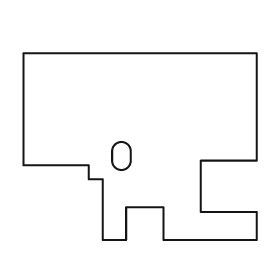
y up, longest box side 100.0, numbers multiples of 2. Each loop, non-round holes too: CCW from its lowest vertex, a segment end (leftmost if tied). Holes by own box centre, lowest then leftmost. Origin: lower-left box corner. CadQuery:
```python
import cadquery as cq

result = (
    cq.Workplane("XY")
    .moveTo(34.0, 0.0)
    .lineTo(44.0, 0.0)
    .lineTo(44.0, 14.0)
    .lineTo(60.0, 14.0)
    .lineTo(60.0, 0.0)
    .lineTo(100.0, 0.0)
    .lineTo(100.0, 12.0)
    .lineTo(76.0, 12.0)
    .lineTo(76.0, 34.0)
    .lineTo(100.0, 34.0)
    .lineTo(100.0, 80.0)
    .lineTo(0.0, 80.0)
    .lineTo(0.0, 32.0)
    .lineTo(28.0, 32.0)
    .lineTo(28.0, 26.0)
    .lineTo(34.0, 26.0)
    .close()
    .moveTo(38.0, 34.0)
    .threePointArc((42.0, 30.0), (46.0, 34.0))
    .lineTo(46.0, 38.0)
    .threePointArc((42.0, 42.0), (38.0, 38.0))
    .close()
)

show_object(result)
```